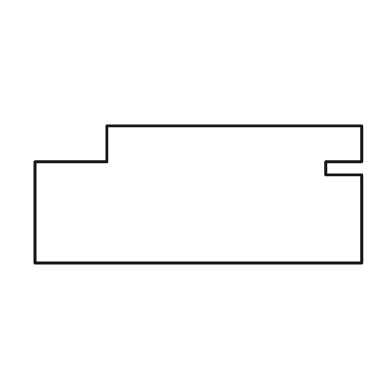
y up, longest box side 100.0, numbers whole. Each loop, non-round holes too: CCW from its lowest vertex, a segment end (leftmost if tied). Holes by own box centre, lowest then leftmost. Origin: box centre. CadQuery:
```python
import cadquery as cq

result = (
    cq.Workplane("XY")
    .moveTo(-50.0, -21.0)
    .lineTo(50.0, -21.0)
    .lineTo(50.0, 6.0)
    .lineTo(39.0, 6.0)
    .lineTo(39.0, 10.0)
    .lineTo(50.0, 10.0)
    .lineTo(50.0, 21.0)
    .lineTo(-28.0, 21.0)
    .lineTo(-28.0, 10.0)
    .lineTo(-50.0, 10.0)
    .close()
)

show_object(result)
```